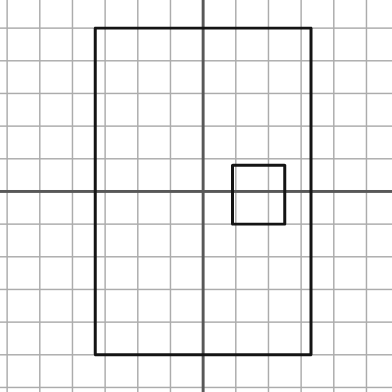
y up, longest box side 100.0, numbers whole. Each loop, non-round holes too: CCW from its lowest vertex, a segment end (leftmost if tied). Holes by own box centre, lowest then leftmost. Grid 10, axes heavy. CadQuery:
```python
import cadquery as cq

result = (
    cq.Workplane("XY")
    .moveTo(-33.0, -50.0)
    .lineTo(33.0, -50.0)
    .lineTo(33.0, 50.0)
    .lineTo(-33.0, 50.0)
    .close()
    .moveTo(9.0, -10.0)
    .lineTo(25.0, -10.0)
    .lineTo(25.0, 8.0)
    .lineTo(9.0, 8.0)
    .close()
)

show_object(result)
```